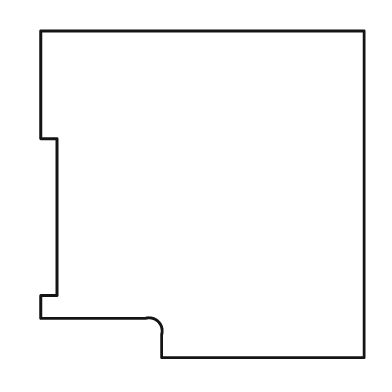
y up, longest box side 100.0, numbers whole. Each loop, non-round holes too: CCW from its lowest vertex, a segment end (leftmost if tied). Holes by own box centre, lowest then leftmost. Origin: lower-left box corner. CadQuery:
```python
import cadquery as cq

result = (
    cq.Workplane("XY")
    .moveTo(37.0, 0.0)
    .lineTo(99.0, 0.0)
    .lineTo(99.0, 100.0)
    .lineTo(0.0, 100.0)
    .lineTo(0.0, 67.0)
    .lineTo(5.0, 67.0)
    .lineTo(5.0, 19.0)
    .lineTo(0.0, 19.0)
    .lineTo(0.0, 12.0)
    .lineTo(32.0, 12.0)
    .threePointArc((36.0, 11.0), (37.0, 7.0))
    .close()
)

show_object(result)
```